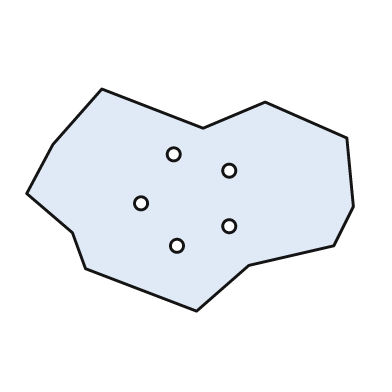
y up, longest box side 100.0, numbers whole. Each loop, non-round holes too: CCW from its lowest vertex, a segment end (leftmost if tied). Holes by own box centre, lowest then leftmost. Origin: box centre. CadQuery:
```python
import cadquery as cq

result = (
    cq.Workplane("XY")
    .moveTo(2.0, -34.0)
    .lineTo(18.0, -20.0)
    .lineTo(44.0, -14.0)
    .lineTo(50.0, -2.0)
    .lineTo(48.0, 19.0)
    .lineTo(23.0, 30.0)
    .lineTo(4.0, 22.0)
    .lineTo(-27.0, 34.0)
    .lineTo(-42.0, 17.0)
    .lineTo(-50.0, 2.0)
    .lineTo(-36.0, -10.0)
    .lineTo(-32.0, -21.0)
    .close()
    .moveTo(-4.0, -14.0)
    .circle(2.0)
    .moveTo(12.0, -8.0)
    .circle(2.0)
    .moveTo(-15.0, -1.0)
    .circle(2.0)
    .moveTo(12.0, 9.0)
    .circle(2.0)
    .moveTo(-5.0, 14.0)
    .circle(2.0)
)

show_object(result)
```